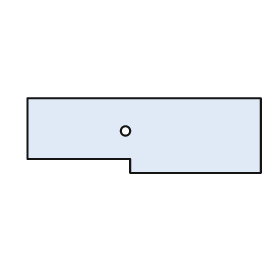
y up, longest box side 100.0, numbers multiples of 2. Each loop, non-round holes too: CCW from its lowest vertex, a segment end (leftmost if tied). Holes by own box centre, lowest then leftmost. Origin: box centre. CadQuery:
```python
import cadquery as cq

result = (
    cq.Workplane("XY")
    .moveTo(-6.0, -16.0)
    .lineTo(50.0, -16.0)
    .lineTo(50.0, 16.0)
    .lineTo(-50.0, 16.0)
    .lineTo(-50.0, -10.0)
    .lineTo(-6.0, -10.0)
    .close()
    .moveTo(-8.0, 2.0)
    .circle(2.0)
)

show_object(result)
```